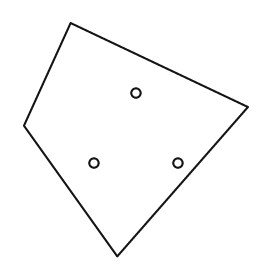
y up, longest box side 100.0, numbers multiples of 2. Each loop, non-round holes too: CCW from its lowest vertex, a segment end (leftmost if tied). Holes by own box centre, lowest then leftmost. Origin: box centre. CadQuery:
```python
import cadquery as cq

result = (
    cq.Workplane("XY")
    .moveTo(-8.0, -50.0)
    .lineTo(48.0, 14.0)
    .lineTo(-28.0, 50.0)
    .lineTo(-48.0, 6.0)
    .close()
    .moveTo(-18.0, -10.0)
    .circle(2.0)
    .moveTo(18.0, -10.0)
    .circle(2.0)
    .moveTo(0.0, 20.0)
    .circle(2.0)
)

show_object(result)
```